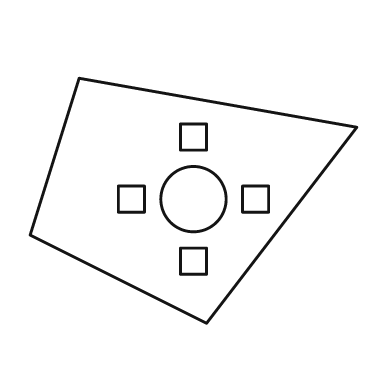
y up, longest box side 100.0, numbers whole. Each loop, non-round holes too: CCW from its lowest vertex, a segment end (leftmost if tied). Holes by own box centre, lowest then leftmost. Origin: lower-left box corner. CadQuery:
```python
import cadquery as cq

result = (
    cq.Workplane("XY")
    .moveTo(54.0, 0.0)
    .lineTo(100.0, 60.0)
    .lineTo(15.0, 75.0)
    .lineTo(0.0, 27.0)
    .close()
    .moveTo(46.0, 15.0)
    .lineTo(54.0, 15.0)
    .lineTo(54.0, 23.0)
    .lineTo(46.0, 23.0)
    .close()
    .moveTo(27.0, 34.0)
    .lineTo(35.0, 34.0)
    .lineTo(35.0, 42.0)
    .lineTo(27.0, 42.0)
    .close()
    .moveTo(50.0, 38.0)
    .circle(10.0)
    .moveTo(65.0, 34.0)
    .lineTo(73.0, 34.0)
    .lineTo(73.0, 42.0)
    .lineTo(65.0, 42.0)
    .close()
    .moveTo(46.0, 53.0)
    .lineTo(54.0, 53.0)
    .lineTo(54.0, 61.0)
    .lineTo(46.0, 61.0)
    .close()
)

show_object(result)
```